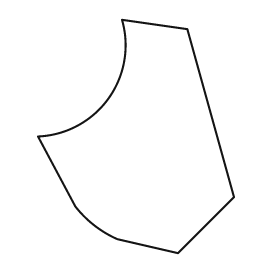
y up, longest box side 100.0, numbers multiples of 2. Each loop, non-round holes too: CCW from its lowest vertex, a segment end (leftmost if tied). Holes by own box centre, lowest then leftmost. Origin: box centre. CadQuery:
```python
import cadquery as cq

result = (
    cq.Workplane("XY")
    .moveTo(18.0, -50.0)
    .lineTo(42.0, -26.0)
    .lineTo(22.0, 46.0)
    .lineTo(-6.0, 50.0)
    .threePointArc((-12.0, 16.0), (-42.0, 0.0))
    .lineTo(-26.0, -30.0)
    .threePointArc((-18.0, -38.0), (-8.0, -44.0))
    .close()
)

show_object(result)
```